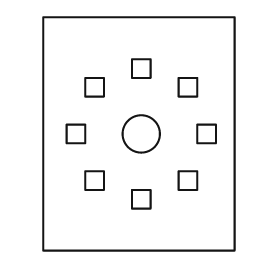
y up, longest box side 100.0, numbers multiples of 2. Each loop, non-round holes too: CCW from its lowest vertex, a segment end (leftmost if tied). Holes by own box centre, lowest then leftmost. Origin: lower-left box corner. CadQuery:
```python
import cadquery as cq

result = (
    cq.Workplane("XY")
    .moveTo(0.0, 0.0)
    .lineTo(82.0, 0.0)
    .lineTo(82.0, 100.0)
    .lineTo(0.0, 100.0)
    .close()
    .moveTo(38.0, 18.0)
    .lineTo(46.0, 18.0)
    .lineTo(46.0, 26.0)
    .lineTo(38.0, 26.0)
    .close()
    .moveTo(18.0, 26.0)
    .lineTo(26.0, 26.0)
    .lineTo(26.0, 34.0)
    .lineTo(18.0, 34.0)
    .close()
    .moveTo(58.0, 26.0)
    .lineTo(66.0, 26.0)
    .lineTo(66.0, 34.0)
    .lineTo(58.0, 34.0)
    .close()
    .moveTo(10.0, 46.0)
    .lineTo(18.0, 46.0)
    .lineTo(18.0, 54.0)
    .lineTo(10.0, 54.0)
    .close()
    .moveTo(42.0, 50.0)
    .circle(8.0)
    .moveTo(66.0, 46.0)
    .lineTo(74.0, 46.0)
    .lineTo(74.0, 54.0)
    .lineTo(66.0, 54.0)
    .close()
    .moveTo(18.0, 66.0)
    .lineTo(26.0, 66.0)
    .lineTo(26.0, 74.0)
    .lineTo(18.0, 74.0)
    .close()
    .moveTo(58.0, 66.0)
    .lineTo(66.0, 66.0)
    .lineTo(66.0, 74.0)
    .lineTo(58.0, 74.0)
    .close()
    .moveTo(38.0, 74.0)
    .lineTo(46.0, 74.0)
    .lineTo(46.0, 82.0)
    .lineTo(38.0, 82.0)
    .close()
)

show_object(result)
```